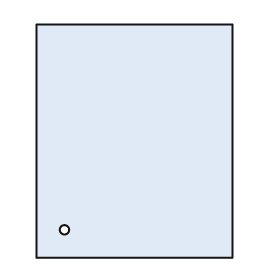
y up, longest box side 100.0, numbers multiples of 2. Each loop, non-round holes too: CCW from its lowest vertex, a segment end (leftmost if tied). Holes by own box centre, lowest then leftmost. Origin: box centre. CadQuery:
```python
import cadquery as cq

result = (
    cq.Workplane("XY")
    .moveTo(-42.0, -50.0)
    .lineTo(42.0, -50.0)
    .lineTo(42.0, 50.0)
    .lineTo(-42.0, 50.0)
    .close()
    .moveTo(-30.0, -38.0)
    .circle(2.0)
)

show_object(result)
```